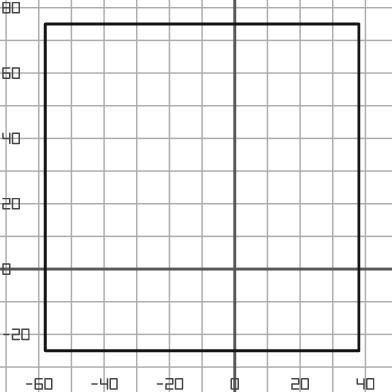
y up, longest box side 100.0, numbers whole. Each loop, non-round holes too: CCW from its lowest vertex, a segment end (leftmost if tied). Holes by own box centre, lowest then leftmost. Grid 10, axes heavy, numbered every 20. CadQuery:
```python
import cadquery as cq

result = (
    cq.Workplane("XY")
    .moveTo(-58.0, -25.0)
    .lineTo(38.0, -25.0)
    .lineTo(38.0, 75.0)
    .lineTo(-58.0, 75.0)
    .close()
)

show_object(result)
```